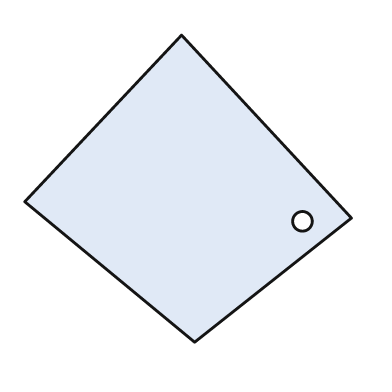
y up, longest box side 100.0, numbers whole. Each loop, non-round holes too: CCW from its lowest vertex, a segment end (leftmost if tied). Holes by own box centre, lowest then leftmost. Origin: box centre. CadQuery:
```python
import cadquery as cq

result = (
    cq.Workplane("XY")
    .moveTo(2.0, -47.0)
    .lineTo(50.0, -9.0)
    .lineTo(-2.0, 47.0)
    .lineTo(-50.0, -4.0)
    .close()
    .moveTo(35.0, -10.0)
    .circle(3.0)
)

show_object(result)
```